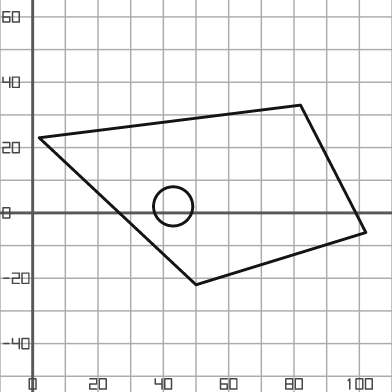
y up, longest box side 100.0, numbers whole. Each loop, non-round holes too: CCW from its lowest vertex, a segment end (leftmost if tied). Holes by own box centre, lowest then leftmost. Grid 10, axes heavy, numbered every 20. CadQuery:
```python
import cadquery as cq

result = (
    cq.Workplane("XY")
    .moveTo(50.0, -22.0)
    .lineTo(102.0, -6.0)
    .lineTo(82.0, 33.0)
    .lineTo(2.0, 23.0)
    .close()
    .moveTo(43.0, 2.0)
    .circle(6.0)
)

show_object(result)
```